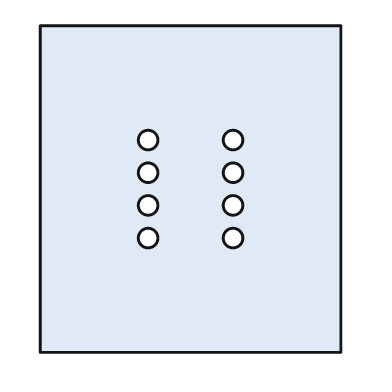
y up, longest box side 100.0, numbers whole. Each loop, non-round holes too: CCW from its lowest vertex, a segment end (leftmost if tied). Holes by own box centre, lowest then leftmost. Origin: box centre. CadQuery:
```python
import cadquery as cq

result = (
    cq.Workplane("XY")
    .moveTo(-46.0, -50.0)
    .lineTo(46.0, -50.0)
    .lineTo(46.0, 50.0)
    .lineTo(-46.0, 50.0)
    .close()
    .moveTo(-13.0, -15.0)
    .circle(3.0)
    .moveTo(13.0, -15.0)
    .circle(3.0)
    .moveTo(-13.0, -5.0)
    .circle(3.0)
    .moveTo(13.0, -5.0)
    .circle(3.0)
    .moveTo(-13.0, 5.0)
    .circle(3.0)
    .moveTo(13.0, 5.0)
    .circle(3.0)
    .moveTo(-13.0, 15.0)
    .circle(3.0)
    .moveTo(13.0, 15.0)
    .circle(3.0)
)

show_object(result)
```